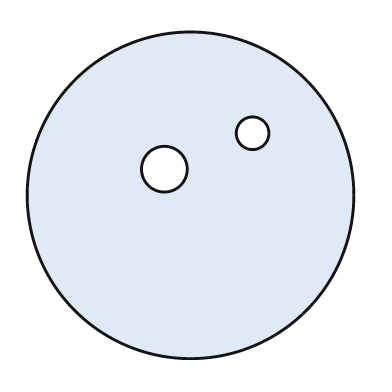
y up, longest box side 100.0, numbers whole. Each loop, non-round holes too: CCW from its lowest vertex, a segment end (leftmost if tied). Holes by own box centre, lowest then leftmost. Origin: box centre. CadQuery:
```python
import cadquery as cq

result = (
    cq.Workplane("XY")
    .moveTo(0.0, 0.0)
    .circle(50.0)
    .moveTo(-8.0, 8.0)
    .circle(7.0)
    .moveTo(19.0, 19.0)
    .circle(5.0)
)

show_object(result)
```